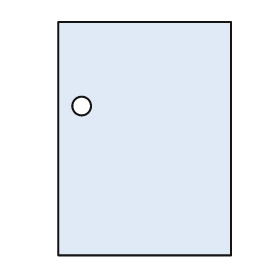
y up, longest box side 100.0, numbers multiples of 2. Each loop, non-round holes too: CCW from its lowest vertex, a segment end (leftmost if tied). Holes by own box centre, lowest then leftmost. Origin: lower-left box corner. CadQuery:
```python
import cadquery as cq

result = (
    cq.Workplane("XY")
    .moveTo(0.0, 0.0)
    .lineTo(74.0, 0.0)
    .lineTo(74.0, 100.0)
    .lineTo(0.0, 100.0)
    .close()
    .moveTo(10.0, 64.0)
    .circle(4.0)
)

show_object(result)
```